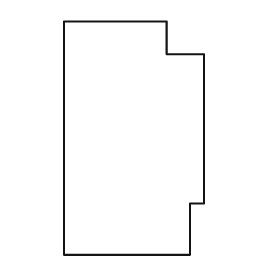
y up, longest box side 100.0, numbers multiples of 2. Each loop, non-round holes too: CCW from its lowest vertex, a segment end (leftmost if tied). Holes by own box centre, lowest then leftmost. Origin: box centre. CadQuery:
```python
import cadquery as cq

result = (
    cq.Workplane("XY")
    .moveTo(-30.0, -50.0)
    .lineTo(24.0, -50.0)
    .lineTo(24.0, -28.0)
    .lineTo(30.0, -28.0)
    .lineTo(30.0, 36.0)
    .lineTo(14.0, 36.0)
    .lineTo(14.0, 50.0)
    .lineTo(-30.0, 50.0)
    .close()
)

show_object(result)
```